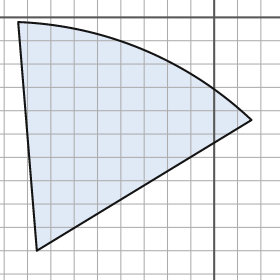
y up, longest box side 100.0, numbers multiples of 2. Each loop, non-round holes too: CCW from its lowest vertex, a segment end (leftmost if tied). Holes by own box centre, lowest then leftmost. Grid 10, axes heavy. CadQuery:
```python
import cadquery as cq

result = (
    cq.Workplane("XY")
    .moveTo(-76.0, -100.0)
    .lineTo(16.0, -44.0)
    .threePointArc((-30.0, -14.0), (-84.0, -2.0))
    .close()
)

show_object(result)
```